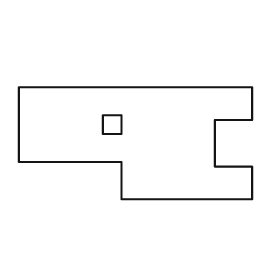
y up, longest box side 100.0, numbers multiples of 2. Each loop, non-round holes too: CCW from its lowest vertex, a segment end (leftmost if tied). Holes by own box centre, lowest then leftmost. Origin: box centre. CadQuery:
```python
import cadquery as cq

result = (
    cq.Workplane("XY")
    .moveTo(-6.0, -24.0)
    .lineTo(50.0, -24.0)
    .lineTo(50.0, -10.0)
    .lineTo(34.0, -10.0)
    .lineTo(34.0, 10.0)
    .lineTo(50.0, 10.0)
    .lineTo(50.0, 24.0)
    .lineTo(-50.0, 24.0)
    .lineTo(-50.0, -8.0)
    .lineTo(-6.0, -8.0)
    .close()
    .moveTo(-14.0, 4.0)
    .lineTo(-6.0, 4.0)
    .lineTo(-6.0, 12.0)
    .lineTo(-14.0, 12.0)
    .close()
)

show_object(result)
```